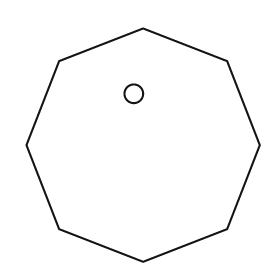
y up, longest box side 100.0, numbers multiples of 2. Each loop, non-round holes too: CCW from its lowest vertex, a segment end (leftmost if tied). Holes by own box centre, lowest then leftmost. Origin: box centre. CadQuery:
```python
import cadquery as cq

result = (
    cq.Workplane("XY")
    .moveTo(0.0, -50.0)
    .lineTo(36.0, -36.0)
    .lineTo(50.0, 0.0)
    .lineTo(36.0, 36.0)
    .lineTo(0.0, 50.0)
    .lineTo(-36.0, 36.0)
    .lineTo(-50.0, 0.0)
    .lineTo(-36.0, -36.0)
    .close()
    .moveTo(-4.0, 22.0)
    .circle(4.0)
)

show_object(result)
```